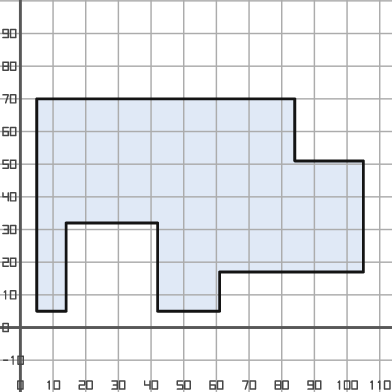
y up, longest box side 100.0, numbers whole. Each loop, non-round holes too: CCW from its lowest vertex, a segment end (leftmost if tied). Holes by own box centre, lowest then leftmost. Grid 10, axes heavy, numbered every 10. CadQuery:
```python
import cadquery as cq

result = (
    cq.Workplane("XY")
    .moveTo(5.0, 5.0)
    .lineTo(14.0, 5.0)
    .lineTo(14.0, 32.0)
    .lineTo(42.0, 32.0)
    .lineTo(42.0, 5.0)
    .lineTo(61.0, 5.0)
    .lineTo(61.0, 17.0)
    .lineTo(105.0, 17.0)
    .lineTo(105.0, 51.0)
    .lineTo(84.0, 51.0)
    .lineTo(84.0, 70.0)
    .lineTo(5.0, 70.0)
    .close()
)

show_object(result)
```